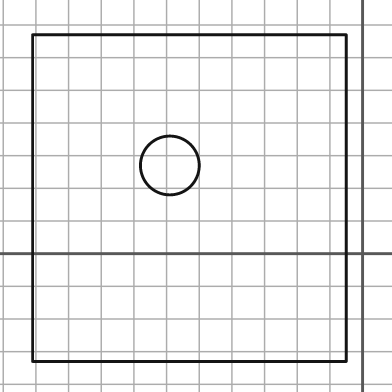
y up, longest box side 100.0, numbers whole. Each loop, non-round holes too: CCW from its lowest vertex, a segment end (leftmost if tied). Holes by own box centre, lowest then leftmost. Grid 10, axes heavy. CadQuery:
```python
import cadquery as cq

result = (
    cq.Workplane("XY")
    .moveTo(-101.0, -33.0)
    .lineTo(-5.0, -33.0)
    .lineTo(-5.0, 67.0)
    .lineTo(-101.0, 67.0)
    .close()
    .moveTo(-59.0, 27.0)
    .circle(9.0)
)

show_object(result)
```